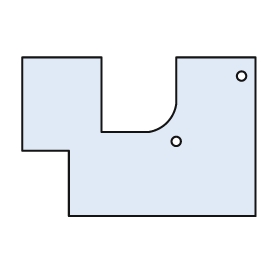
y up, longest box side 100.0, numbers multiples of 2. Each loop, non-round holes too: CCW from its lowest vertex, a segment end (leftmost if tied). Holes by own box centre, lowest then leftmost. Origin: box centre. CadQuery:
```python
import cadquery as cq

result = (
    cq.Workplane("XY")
    .moveTo(-30.0, -34.0)
    .lineTo(50.0, -34.0)
    .lineTo(50.0, 34.0)
    .lineTo(16.0, 34.0)
    .lineTo(16.0, 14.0)
    .threePointArc((12.0, 6.0), (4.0, 2.0))
    .lineTo(-16.0, 2.0)
    .lineTo(-16.0, 34.0)
    .lineTo(-50.0, 34.0)
    .lineTo(-50.0, -6.0)
    .lineTo(-30.0, -6.0)
    .close()
    .moveTo(16.0, -2.0)
    .circle(2.0)
    .moveTo(44.0, 26.0)
    .circle(2.0)
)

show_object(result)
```